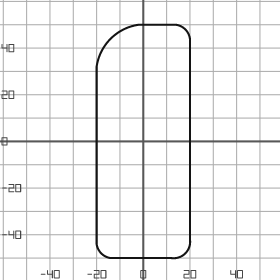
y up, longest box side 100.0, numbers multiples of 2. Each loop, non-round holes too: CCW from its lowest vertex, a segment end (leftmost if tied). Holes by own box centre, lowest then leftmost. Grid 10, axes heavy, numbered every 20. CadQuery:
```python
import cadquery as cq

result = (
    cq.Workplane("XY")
    .moveTo(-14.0, -50.0)
    .lineTo(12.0, -50.0)
    .threePointArc((18.0, -48.0), (20.0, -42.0))
    .lineTo(20.0, 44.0)
    .threePointArc((18.0, 48.0), (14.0, 50.0))
    .lineTo(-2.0, 50.0)
    .threePointArc((-14.0, 44.0), (-20.0, 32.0))
    .lineTo(-20.0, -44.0)
    .threePointArc((-18.0, -48.0), (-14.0, -50.0))
    .close()
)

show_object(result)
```